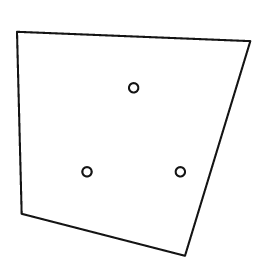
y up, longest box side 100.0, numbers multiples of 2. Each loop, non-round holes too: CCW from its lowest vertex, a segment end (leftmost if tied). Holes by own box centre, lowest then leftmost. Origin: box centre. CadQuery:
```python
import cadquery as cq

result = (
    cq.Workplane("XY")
    .moveTo(22.0, -48.0)
    .lineTo(50.0, 44.0)
    .lineTo(-50.0, 48.0)
    .lineTo(-48.0, -30.0)
    .close()
    .moveTo(-20.0, -12.0)
    .circle(2.0)
    .moveTo(20.0, -12.0)
    .circle(2.0)
    .moveTo(0.0, 24.0)
    .circle(2.0)
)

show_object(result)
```